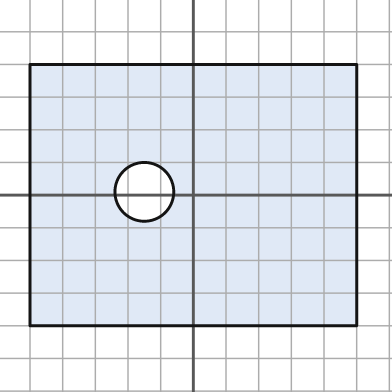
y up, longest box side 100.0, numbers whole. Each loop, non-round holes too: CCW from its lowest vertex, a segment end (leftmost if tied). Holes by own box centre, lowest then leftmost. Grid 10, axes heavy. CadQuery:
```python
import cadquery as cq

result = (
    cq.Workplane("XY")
    .moveTo(-50.0, -40.0)
    .lineTo(50.0, -40.0)
    .lineTo(50.0, 40.0)
    .lineTo(-50.0, 40.0)
    .close()
    .moveTo(-15.0, 1.0)
    .circle(9.0)
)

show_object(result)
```